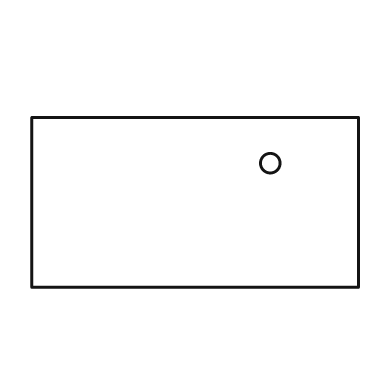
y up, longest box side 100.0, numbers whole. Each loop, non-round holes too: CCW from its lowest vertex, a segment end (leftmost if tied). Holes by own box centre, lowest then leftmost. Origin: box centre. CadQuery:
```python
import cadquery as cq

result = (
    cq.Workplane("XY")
    .moveTo(-50.0, -26.0)
    .lineTo(50.0, -26.0)
    .lineTo(50.0, 26.0)
    .lineTo(-50.0, 26.0)
    .close()
    .moveTo(23.0, 12.0)
    .circle(3.0)
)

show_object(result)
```